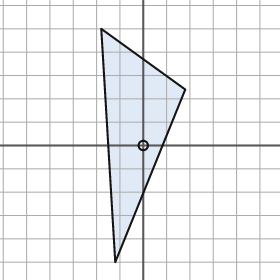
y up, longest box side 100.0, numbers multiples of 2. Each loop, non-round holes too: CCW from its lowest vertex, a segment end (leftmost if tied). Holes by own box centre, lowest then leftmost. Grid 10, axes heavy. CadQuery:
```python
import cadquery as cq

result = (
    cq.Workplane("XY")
    .moveTo(-12.0, -50.0)
    .lineTo(18.0, 24.0)
    .lineTo(-18.0, 50.0)
    .close()
    .moveTo(0.0, 0.0)
    .circle(2.0)
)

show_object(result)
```